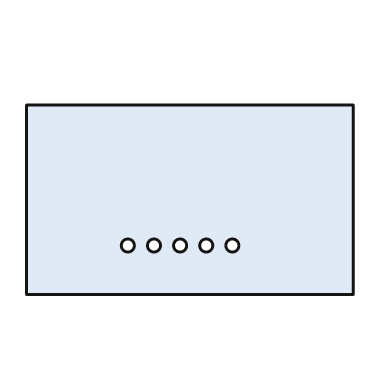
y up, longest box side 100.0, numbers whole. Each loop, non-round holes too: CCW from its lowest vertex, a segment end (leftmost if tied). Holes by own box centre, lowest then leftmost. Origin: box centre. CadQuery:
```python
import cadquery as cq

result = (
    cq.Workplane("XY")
    .moveTo(-50.0, -29.0)
    .lineTo(50.0, -29.0)
    .lineTo(50.0, 29.0)
    .lineTo(-50.0, 29.0)
    .close()
    .moveTo(-19.0, -14.0)
    .circle(2.0)
    .moveTo(-11.0, -14.0)
    .circle(2.0)
    .moveTo(-3.0, -14.0)
    .circle(2.0)
    .moveTo(5.0, -14.0)
    .circle(2.0)
    .moveTo(13.0, -14.0)
    .circle(2.0)
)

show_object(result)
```